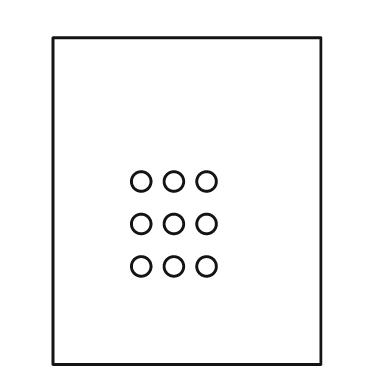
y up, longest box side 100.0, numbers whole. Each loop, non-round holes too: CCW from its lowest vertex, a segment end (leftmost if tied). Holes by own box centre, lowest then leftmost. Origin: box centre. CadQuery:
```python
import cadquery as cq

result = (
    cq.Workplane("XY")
    .moveTo(-41.0, -50.0)
    .lineTo(41.0, -50.0)
    .lineTo(41.0, 50.0)
    .lineTo(-41.0, 50.0)
    .close()
    .moveTo(-14.0, -20.0)
    .circle(3.0)
    .moveTo(-4.0, -20.0)
    .circle(3.0)
    .moveTo(6.0, -20.0)
    .circle(3.0)
    .moveTo(-14.0, -7.0)
    .circle(3.0)
    .moveTo(-4.0, -7.0)
    .circle(3.0)
    .moveTo(6.0, -7.0)
    .circle(3.0)
    .moveTo(-14.0, 6.0)
    .circle(3.0)
    .moveTo(-4.0, 6.0)
    .circle(3.0)
    .moveTo(6.0, 6.0)
    .circle(3.0)
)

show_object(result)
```